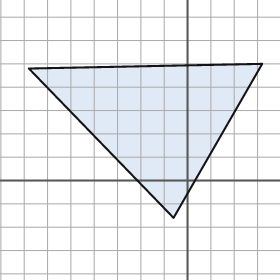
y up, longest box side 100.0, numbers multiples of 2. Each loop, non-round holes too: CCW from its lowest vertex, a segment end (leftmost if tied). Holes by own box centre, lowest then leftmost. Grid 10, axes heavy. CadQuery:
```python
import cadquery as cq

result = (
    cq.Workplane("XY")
    .moveTo(-6.0, -16.0)
    .lineTo(32.0, 50.0)
    .lineTo(-68.0, 48.0)
    .close()
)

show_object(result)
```